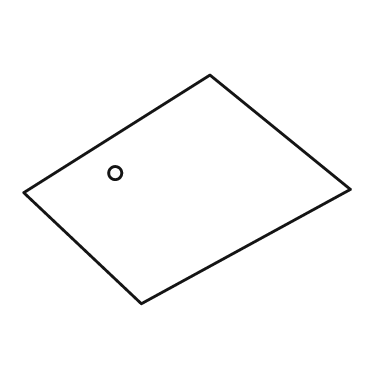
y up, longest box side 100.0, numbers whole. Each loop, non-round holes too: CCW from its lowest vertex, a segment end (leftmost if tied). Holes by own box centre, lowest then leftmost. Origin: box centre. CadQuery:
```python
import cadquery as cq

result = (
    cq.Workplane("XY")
    .moveTo(-14.0, -35.0)
    .lineTo(50.0, 0.0)
    .lineTo(7.0, 35.0)
    .lineTo(-50.0, -1.0)
    .close()
    .moveTo(-22.0, 5.0)
    .circle(2.0)
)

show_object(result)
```